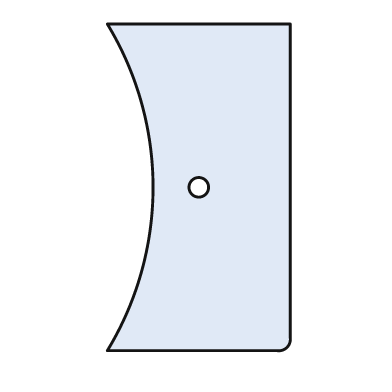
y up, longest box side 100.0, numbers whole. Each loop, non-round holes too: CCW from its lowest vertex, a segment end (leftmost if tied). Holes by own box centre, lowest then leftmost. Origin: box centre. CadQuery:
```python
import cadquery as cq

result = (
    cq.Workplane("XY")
    .moveTo(-28.0, -50.0)
    .lineTo(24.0, -50.0)
    .threePointArc((27.0, -49.0), (28.0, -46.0))
    .lineTo(28.0, 50.0)
    .lineTo(-28.0, 50.0)
    .threePointArc((-14.0, 0.0), (-28.0, -50.0))
    .close()
    .moveTo(0.0, 0.0)
    .circle(3.0)
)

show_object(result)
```